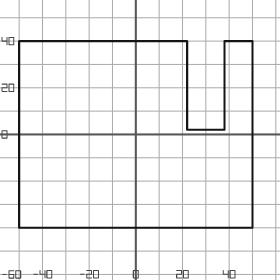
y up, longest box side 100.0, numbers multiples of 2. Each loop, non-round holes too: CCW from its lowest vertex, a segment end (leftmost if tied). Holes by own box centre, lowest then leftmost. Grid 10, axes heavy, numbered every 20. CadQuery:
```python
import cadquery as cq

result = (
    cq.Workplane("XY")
    .moveTo(-50.0, -40.0)
    .lineTo(50.0, -40.0)
    .lineTo(50.0, 40.0)
    .lineTo(38.0, 40.0)
    .lineTo(38.0, 2.0)
    .lineTo(22.0, 2.0)
    .lineTo(22.0, 40.0)
    .lineTo(-50.0, 40.0)
    .close()
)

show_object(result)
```